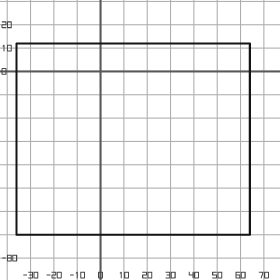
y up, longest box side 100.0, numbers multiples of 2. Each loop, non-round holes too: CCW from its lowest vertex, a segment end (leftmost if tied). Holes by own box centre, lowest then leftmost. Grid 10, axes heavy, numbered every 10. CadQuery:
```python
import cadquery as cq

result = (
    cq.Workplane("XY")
    .moveTo(-36.0, -70.0)
    .lineTo(64.0, -70.0)
    .lineTo(64.0, 12.0)
    .lineTo(-36.0, 12.0)
    .close()
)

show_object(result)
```